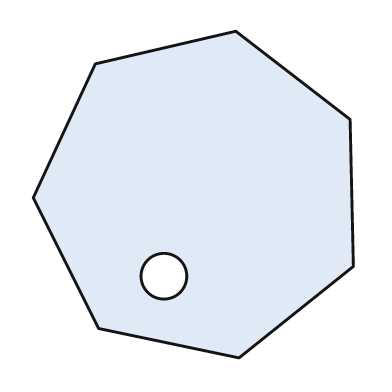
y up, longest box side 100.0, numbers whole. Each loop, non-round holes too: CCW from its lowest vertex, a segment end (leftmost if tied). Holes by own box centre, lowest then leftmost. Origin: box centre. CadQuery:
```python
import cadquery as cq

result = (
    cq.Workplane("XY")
    .moveTo(14.0, -50.0)
    .lineTo(49.0, -22.0)
    .lineTo(48.0, 23.0)
    .lineTo(13.0, 50.0)
    .lineTo(-30.0, 40.0)
    .lineTo(-49.0, -1.0)
    .lineTo(-29.0, -41.0)
    .close()
    .moveTo(-9.0, -25.0)
    .circle(7.0)
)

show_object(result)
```